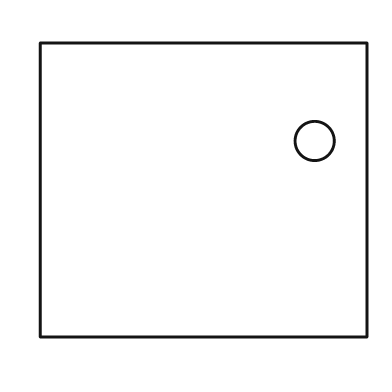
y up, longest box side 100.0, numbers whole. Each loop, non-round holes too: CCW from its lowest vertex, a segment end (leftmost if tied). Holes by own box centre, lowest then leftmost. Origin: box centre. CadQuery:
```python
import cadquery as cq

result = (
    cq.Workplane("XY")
    .moveTo(-50.0, -45.0)
    .lineTo(50.0, -45.0)
    .lineTo(50.0, 45.0)
    .lineTo(-50.0, 45.0)
    .close()
    .moveTo(34.0, 15.0)
    .circle(6.0)
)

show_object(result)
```